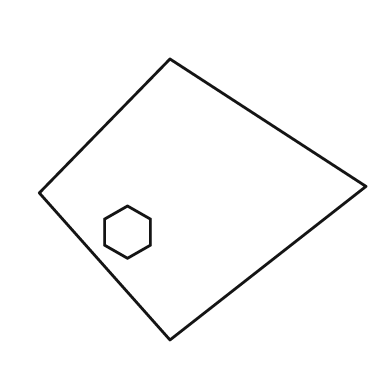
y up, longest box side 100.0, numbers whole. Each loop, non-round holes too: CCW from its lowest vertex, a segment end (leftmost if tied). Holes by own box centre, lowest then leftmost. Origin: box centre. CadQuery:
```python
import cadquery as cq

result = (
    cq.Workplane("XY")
    .moveTo(-10.0, -43.0)
    .lineTo(50.0, 4.0)
    .lineTo(-10.0, 43.0)
    .lineTo(-50.0, 2.0)
    .close()
    .moveTo(-23.0, -18.0)
    .lineTo(-16.0, -14.0)
    .lineTo(-16.0, -6.0)
    .lineTo(-23.0, -2.0)
    .lineTo(-30.0, -6.0)
    .lineTo(-30.0, -14.0)
    .close()
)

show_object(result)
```